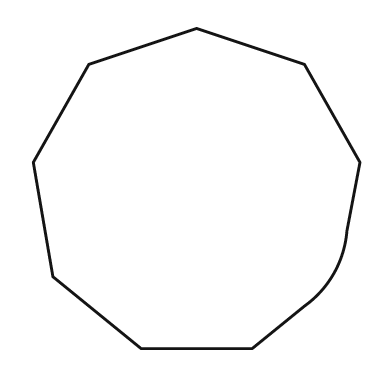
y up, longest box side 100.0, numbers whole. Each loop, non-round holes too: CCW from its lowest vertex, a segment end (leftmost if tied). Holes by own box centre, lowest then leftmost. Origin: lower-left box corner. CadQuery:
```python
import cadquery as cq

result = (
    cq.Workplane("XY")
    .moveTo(33.0, 0.0)
    .lineTo(67.0, 0.0)
    .lineTo(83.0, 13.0)
    .threePointArc((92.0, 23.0), (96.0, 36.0))
    .lineTo(100.0, 57.0)
    .lineTo(83.0, 87.0)
    .lineTo(50.0, 98.0)
    .lineTo(17.0, 87.0)
    .lineTo(0.0, 57.0)
    .lineTo(6.0, 22.0)
    .close()
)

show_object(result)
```